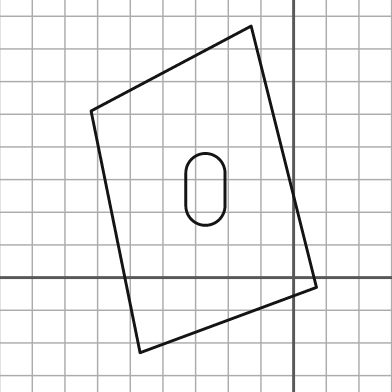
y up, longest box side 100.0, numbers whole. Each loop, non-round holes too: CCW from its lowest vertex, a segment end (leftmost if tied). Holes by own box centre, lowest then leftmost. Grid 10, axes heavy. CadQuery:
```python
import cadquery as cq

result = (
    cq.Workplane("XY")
    .moveTo(-47.0, -23.0)
    .lineTo(7.0, -3.0)
    .lineTo(-13.0, 77.0)
    .lineTo(-62.0, 51.0)
    .close()
    .moveTo(-33.0, 22.0)
    .threePointArc((-27.0, 16.0), (-21.0, 22.0))
    .lineTo(-21.0, 32.0)
    .threePointArc((-27.0, 38.0), (-33.0, 32.0))
    .close()
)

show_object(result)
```